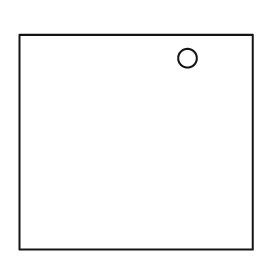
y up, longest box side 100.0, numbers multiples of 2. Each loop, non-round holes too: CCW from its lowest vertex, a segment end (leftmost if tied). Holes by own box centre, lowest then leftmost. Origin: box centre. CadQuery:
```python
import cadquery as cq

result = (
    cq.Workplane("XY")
    .moveTo(-50.0, -46.0)
    .lineTo(50.0, -46.0)
    .lineTo(50.0, 46.0)
    .lineTo(-50.0, 46.0)
    .close()
    .moveTo(22.0, 36.0)
    .circle(4.0)
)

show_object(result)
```